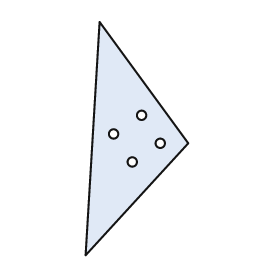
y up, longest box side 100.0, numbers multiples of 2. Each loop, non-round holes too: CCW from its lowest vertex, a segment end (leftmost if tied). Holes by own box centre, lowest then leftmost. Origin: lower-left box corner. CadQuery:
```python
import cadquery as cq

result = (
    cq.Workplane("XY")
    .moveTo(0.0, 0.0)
    .lineTo(44.0, 48.0)
    .lineTo(6.0, 100.0)
    .close()
    .moveTo(20.0, 40.0)
    .circle(2.0)
    .moveTo(32.0, 48.0)
    .circle(2.0)
    .moveTo(12.0, 52.0)
    .circle(2.0)
    .moveTo(24.0, 60.0)
    .circle(2.0)
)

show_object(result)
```